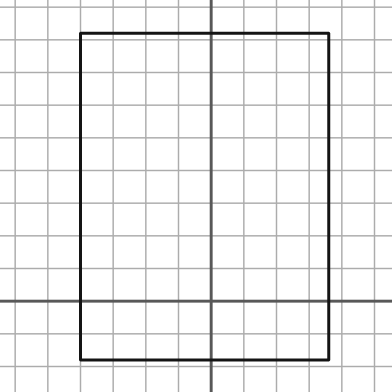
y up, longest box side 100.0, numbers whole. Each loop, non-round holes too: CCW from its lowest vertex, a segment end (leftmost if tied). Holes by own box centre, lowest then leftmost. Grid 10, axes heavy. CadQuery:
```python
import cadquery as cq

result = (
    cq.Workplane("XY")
    .moveTo(-40.0, -18.0)
    .lineTo(36.0, -18.0)
    .lineTo(36.0, 82.0)
    .lineTo(-40.0, 82.0)
    .close()
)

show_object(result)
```